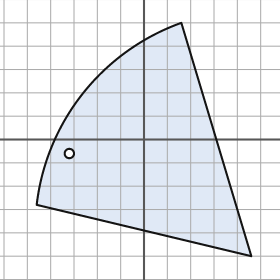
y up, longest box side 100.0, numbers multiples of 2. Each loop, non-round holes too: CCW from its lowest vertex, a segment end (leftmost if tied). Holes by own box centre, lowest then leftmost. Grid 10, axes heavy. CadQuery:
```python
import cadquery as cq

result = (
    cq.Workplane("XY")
    .moveTo(46.0, -50.0)
    .lineTo(16.0, 50.0)
    .threePointArc((-26.0, 20.0), (-46.0, -28.0))
    .close()
    .moveTo(-32.0, -6.0)
    .circle(2.0)
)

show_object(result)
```